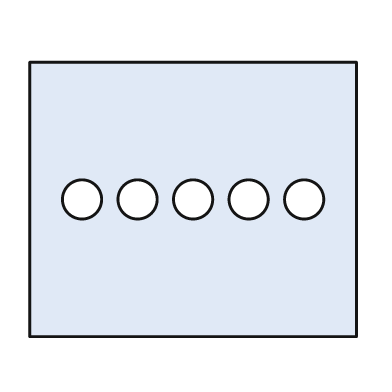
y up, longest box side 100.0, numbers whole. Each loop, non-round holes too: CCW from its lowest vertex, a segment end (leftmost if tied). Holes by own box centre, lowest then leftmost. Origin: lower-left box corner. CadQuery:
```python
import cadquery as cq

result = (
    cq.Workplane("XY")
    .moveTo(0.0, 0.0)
    .lineTo(100.0, 0.0)
    .lineTo(100.0, 84.0)
    .lineTo(0.0, 84.0)
    .close()
    .moveTo(16.0, 42.0)
    .circle(6.0)
    .moveTo(33.0, 42.0)
    .circle(6.0)
    .moveTo(50.0, 42.0)
    .circle(6.0)
    .moveTo(67.0, 42.0)
    .circle(6.0)
    .moveTo(84.0, 42.0)
    .circle(6.0)
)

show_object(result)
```